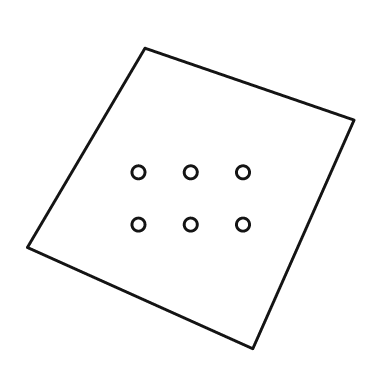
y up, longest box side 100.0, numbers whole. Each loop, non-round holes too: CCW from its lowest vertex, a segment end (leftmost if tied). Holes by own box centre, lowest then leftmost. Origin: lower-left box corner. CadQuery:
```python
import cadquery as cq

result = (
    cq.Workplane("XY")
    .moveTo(69.0, 0.0)
    .lineTo(100.0, 70.0)
    .lineTo(36.0, 92.0)
    .lineTo(0.0, 31.0)
    .close()
    .moveTo(34.0, 38.0)
    .circle(2.0)
    .moveTo(50.0, 38.0)
    .circle(2.0)
    .moveTo(66.0, 38.0)
    .circle(2.0)
    .moveTo(34.0, 54.0)
    .circle(2.0)
    .moveTo(50.0, 54.0)
    .circle(2.0)
    .moveTo(66.0, 54.0)
    .circle(2.0)
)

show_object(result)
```